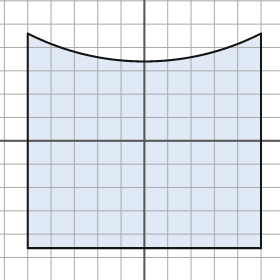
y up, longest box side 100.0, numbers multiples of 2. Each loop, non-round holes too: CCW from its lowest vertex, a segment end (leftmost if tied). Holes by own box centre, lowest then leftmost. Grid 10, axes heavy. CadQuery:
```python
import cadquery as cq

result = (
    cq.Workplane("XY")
    .moveTo(-50.0, -46.0)
    .lineTo(50.0, -46.0)
    .lineTo(50.0, 46.0)
    .threePointArc((0.0, 34.0), (-50.0, 46.0))
    .close()
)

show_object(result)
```